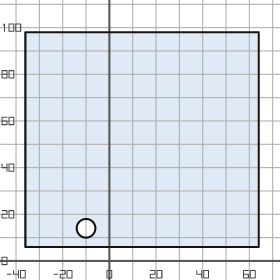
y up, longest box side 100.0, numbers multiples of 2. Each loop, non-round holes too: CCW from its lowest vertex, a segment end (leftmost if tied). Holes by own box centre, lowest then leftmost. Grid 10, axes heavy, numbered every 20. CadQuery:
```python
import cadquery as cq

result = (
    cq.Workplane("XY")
    .moveTo(-36.0, 6.0)
    .lineTo(64.0, 6.0)
    .lineTo(64.0, 98.0)
    .lineTo(-36.0, 98.0)
    .close()
    .moveTo(-10.0, 14.0)
    .circle(4.0)
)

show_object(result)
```